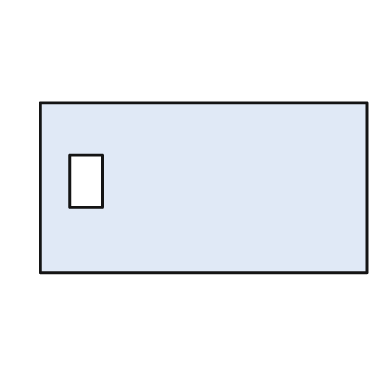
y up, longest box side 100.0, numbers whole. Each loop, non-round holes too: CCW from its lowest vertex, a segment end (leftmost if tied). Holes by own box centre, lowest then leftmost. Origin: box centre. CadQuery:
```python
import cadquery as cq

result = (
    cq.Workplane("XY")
    .moveTo(-50.0, -26.0)
    .lineTo(50.0, -26.0)
    .lineTo(50.0, 26.0)
    .lineTo(-50.0, 26.0)
    .close()
    .moveTo(-41.0, -6.0)
    .lineTo(-31.0, -6.0)
    .lineTo(-31.0, 10.0)
    .lineTo(-41.0, 10.0)
    .close()
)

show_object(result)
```